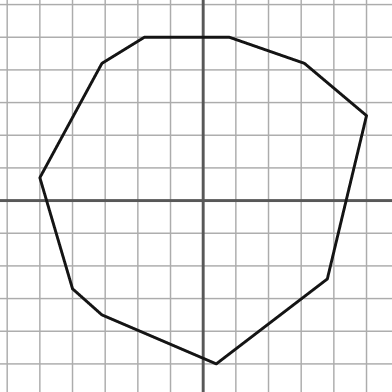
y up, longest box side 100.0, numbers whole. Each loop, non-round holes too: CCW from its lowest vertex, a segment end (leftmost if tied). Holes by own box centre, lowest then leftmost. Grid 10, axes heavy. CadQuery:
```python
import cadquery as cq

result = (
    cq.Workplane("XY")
    .moveTo(4.0, -50.0)
    .lineTo(38.0, -24.0)
    .lineTo(50.0, 26.0)
    .lineTo(31.0, 42.0)
    .lineTo(8.0, 50.0)
    .lineTo(-18.0, 50.0)
    .lineTo(-31.0, 42.0)
    .lineTo(-50.0, 7.0)
    .lineTo(-40.0, -27.0)
    .lineTo(-31.0, -35.0)
    .close()
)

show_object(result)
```